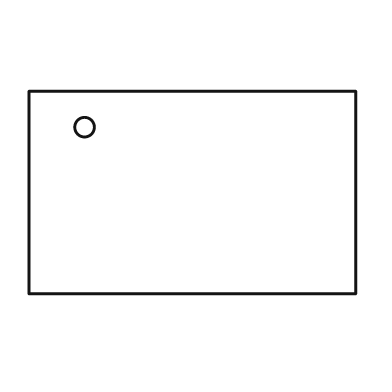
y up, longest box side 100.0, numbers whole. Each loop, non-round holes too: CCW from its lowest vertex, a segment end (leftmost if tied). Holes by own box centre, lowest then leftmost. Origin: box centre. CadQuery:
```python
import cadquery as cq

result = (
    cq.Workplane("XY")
    .moveTo(-50.0, -31.0)
    .lineTo(50.0, -31.0)
    .lineTo(50.0, 31.0)
    .lineTo(-50.0, 31.0)
    .close()
    .moveTo(-33.0, 20.0)
    .circle(3.0)
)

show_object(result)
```